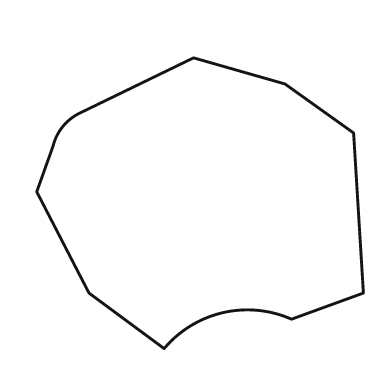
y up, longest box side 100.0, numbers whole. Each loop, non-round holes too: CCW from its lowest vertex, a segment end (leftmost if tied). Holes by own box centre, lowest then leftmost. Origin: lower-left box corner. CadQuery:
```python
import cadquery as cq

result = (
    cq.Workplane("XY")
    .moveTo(39.0, 0.0)
    .threePointArc((57.0, 11.0), (78.0, 9.0))
    .lineTo(100.0, 17.0)
    .lineTo(97.0, 66.0)
    .lineTo(76.0, 81.0)
    .lineTo(48.0, 89.0)
    .lineTo(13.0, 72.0)
    .threePointArc((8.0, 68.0), (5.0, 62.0))
    .lineTo(0.0, 48.0)
    .lineTo(16.0, 17.0)
    .close()
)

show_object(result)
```